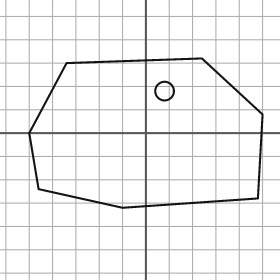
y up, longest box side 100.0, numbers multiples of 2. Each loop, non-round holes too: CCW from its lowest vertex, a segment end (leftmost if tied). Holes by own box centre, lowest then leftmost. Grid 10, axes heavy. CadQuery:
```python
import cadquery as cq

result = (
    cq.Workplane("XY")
    .moveTo(-10.0, -32.0)
    .lineTo(48.0, -28.0)
    .lineTo(50.0, 8.0)
    .lineTo(24.0, 32.0)
    .lineTo(-34.0, 30.0)
    .lineTo(-50.0, 0.0)
    .lineTo(-46.0, -24.0)
    .close()
    .moveTo(8.0, 18.0)
    .circle(4.0)
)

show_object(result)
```